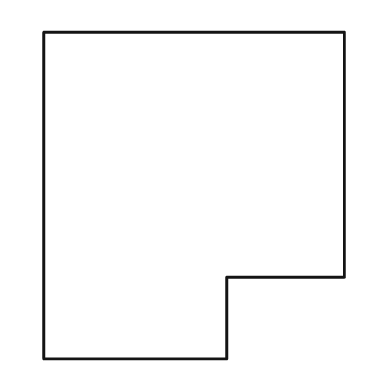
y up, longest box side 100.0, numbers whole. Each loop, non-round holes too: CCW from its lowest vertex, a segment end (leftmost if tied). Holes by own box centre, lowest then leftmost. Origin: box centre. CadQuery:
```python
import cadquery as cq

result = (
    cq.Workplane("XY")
    .moveTo(-46.0, -50.0)
    .lineTo(10.0, -50.0)
    .lineTo(10.0, -25.0)
    .lineTo(46.0, -25.0)
    .lineTo(46.0, 50.0)
    .lineTo(-46.0, 50.0)
    .close()
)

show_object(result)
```